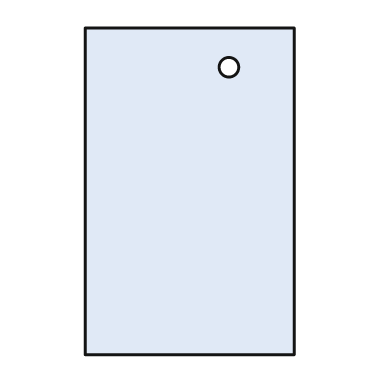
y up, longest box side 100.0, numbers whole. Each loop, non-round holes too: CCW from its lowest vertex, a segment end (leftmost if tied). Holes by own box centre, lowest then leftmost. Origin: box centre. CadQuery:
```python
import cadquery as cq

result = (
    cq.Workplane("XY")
    .moveTo(-32.0, -50.0)
    .lineTo(32.0, -50.0)
    .lineTo(32.0, 50.0)
    .lineTo(-32.0, 50.0)
    .close()
    .moveTo(12.0, 38.0)
    .circle(3.0)
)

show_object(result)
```